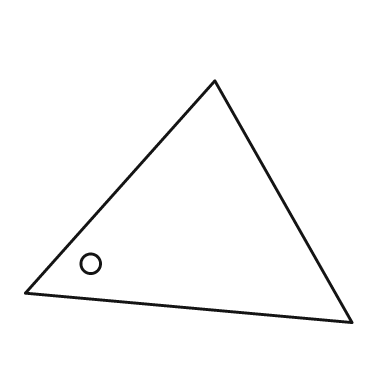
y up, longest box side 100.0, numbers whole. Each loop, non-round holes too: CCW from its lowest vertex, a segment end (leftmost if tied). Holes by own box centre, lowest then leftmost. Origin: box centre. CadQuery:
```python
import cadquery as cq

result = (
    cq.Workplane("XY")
    .moveTo(50.0, -37.0)
    .lineTo(8.0, 37.0)
    .lineTo(-50.0, -28.0)
    .close()
    .moveTo(-30.0, -19.0)
    .circle(3.0)
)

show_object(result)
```